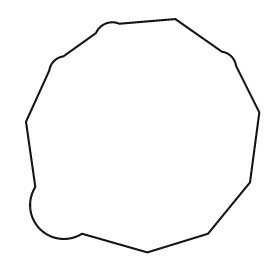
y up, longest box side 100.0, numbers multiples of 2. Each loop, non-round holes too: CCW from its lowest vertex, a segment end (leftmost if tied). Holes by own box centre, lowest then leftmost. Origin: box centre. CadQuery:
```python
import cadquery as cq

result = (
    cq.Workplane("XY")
    .moveTo(2.0, -50.0)
    .lineTo(28.0, -42.0)
    .lineTo(46.0, -20.0)
    .lineTo(50.0, 10.0)
    .lineTo(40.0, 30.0)
    .threePointArc((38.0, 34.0), (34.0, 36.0))
    .lineTo(14.0, 50.0)
    .lineTo(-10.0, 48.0)
    .threePointArc((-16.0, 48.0), (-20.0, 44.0))
    .lineTo(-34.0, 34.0)
    .threePointArc((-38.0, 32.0), (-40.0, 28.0))
    .lineTo(-50.0, 6.0)
    .lineTo(-46.0, -22.0)
    .threePointArc((-44.0, -40.0), (-26.0, -42.0))
    .close()
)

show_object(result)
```